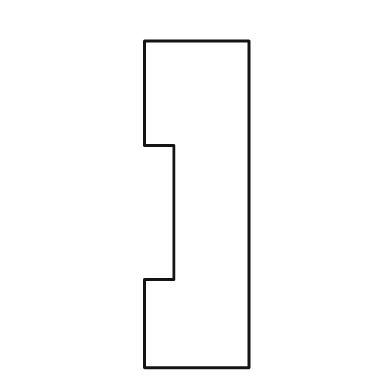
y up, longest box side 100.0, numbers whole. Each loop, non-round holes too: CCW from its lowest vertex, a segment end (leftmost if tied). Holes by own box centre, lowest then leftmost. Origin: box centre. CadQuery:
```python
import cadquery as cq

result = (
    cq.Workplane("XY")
    .moveTo(-16.0, -50.0)
    .lineTo(16.0, -50.0)
    .lineTo(16.0, 50.0)
    .lineTo(-16.0, 50.0)
    .lineTo(-16.0, 18.0)
    .lineTo(-7.0, 18.0)
    .lineTo(-7.0, -23.0)
    .lineTo(-16.0, -23.0)
    .close()
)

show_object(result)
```